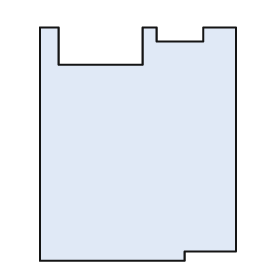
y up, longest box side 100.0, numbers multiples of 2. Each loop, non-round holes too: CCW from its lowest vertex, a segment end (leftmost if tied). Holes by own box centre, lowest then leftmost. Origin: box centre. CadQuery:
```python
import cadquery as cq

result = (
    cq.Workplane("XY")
    .moveTo(-42.0, -50.0)
    .lineTo(20.0, -50.0)
    .lineTo(20.0, -46.0)
    .lineTo(42.0, -46.0)
    .lineTo(42.0, 50.0)
    .lineTo(28.0, 50.0)
    .lineTo(28.0, 44.0)
    .lineTo(8.0, 44.0)
    .lineTo(8.0, 50.0)
    .lineTo(2.0, 50.0)
    .lineTo(2.0, 34.0)
    .lineTo(-34.0, 34.0)
    .lineTo(-34.0, 50.0)
    .lineTo(-42.0, 50.0)
    .close()
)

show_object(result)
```